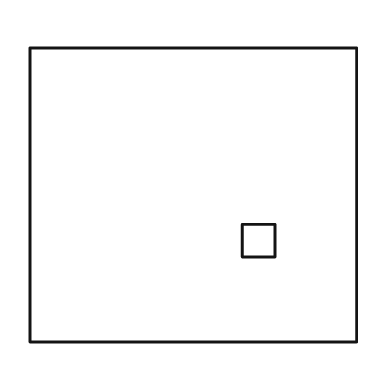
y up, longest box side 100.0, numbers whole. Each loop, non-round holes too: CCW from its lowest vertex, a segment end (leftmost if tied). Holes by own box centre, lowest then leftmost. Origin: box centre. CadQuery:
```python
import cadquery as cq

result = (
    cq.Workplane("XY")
    .moveTo(-50.0, -45.0)
    .lineTo(50.0, -45.0)
    .lineTo(50.0, 45.0)
    .lineTo(-50.0, 45.0)
    .close()
    .moveTo(15.0, -19.0)
    .lineTo(25.0, -19.0)
    .lineTo(25.0, -9.0)
    .lineTo(15.0, -9.0)
    .close()
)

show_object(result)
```